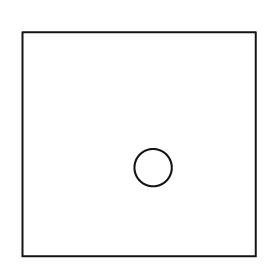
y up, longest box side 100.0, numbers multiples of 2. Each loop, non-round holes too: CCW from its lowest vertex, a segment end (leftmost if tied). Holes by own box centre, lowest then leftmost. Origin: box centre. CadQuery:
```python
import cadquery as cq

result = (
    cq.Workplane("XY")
    .moveTo(-50.0, -48.0)
    .lineTo(50.0, -48.0)
    .lineTo(50.0, 48.0)
    .lineTo(-50.0, 48.0)
    .close()
    .moveTo(6.0, -10.0)
    .circle(8.0)
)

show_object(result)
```